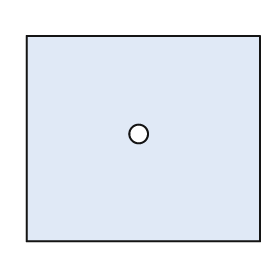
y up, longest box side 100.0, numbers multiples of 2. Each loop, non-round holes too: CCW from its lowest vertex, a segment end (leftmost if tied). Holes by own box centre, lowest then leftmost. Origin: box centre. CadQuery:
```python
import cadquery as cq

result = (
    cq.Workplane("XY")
    .moveTo(-50.0, -44.0)
    .lineTo(50.0, -44.0)
    .lineTo(50.0, 44.0)
    .lineTo(-50.0, 44.0)
    .close()
    .moveTo(-2.0, 2.0)
    .circle(4.0)
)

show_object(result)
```